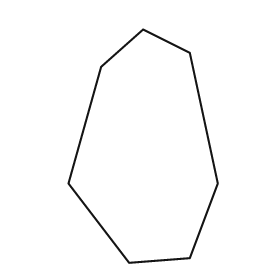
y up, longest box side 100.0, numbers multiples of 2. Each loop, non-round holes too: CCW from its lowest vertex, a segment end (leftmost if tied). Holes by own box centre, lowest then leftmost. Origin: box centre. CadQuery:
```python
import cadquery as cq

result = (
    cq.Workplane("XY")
    .moveTo(-6.0, -50.0)
    .lineTo(20.0, -48.0)
    .lineTo(32.0, -16.0)
    .lineTo(20.0, 40.0)
    .lineTo(0.0, 50.0)
    .lineTo(-18.0, 34.0)
    .lineTo(-32.0, -16.0)
    .close()
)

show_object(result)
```